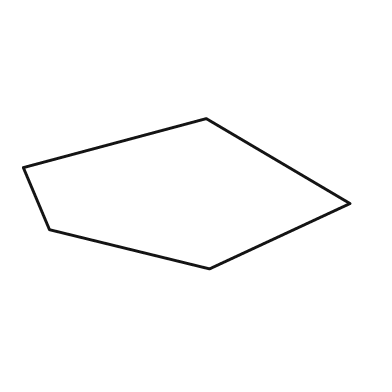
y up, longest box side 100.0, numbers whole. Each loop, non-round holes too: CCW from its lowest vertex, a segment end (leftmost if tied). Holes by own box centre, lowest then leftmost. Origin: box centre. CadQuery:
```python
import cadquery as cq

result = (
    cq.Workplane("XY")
    .moveTo(7.0, -23.0)
    .lineTo(50.0, -3.0)
    .lineTo(6.0, 23.0)
    .lineTo(-50.0, 8.0)
    .lineTo(-42.0, -11.0)
    .close()
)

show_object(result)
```